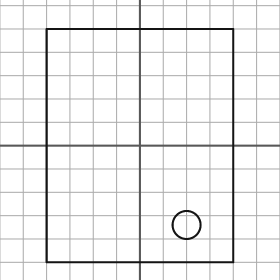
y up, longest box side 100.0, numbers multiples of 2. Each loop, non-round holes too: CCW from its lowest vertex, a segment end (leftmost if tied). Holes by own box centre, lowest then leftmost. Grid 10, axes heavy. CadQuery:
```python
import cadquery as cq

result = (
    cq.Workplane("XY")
    .moveTo(-40.0, -50.0)
    .lineTo(40.0, -50.0)
    .lineTo(40.0, 50.0)
    .lineTo(-40.0, 50.0)
    .close()
    .moveTo(20.0, -34.0)
    .circle(6.0)
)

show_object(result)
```